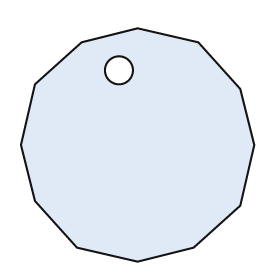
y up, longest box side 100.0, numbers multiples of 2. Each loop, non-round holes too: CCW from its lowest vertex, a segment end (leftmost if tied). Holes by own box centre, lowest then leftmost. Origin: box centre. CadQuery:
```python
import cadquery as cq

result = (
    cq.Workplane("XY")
    .moveTo(0.0, -50.0)
    .lineTo(24.0, -44.0)
    .lineTo(44.0, -26.0)
    .lineTo(50.0, 0.0)
    .lineTo(44.0, 24.0)
    .lineTo(26.0, 44.0)
    .lineTo(0.0, 50.0)
    .lineTo(-24.0, 44.0)
    .lineTo(-44.0, 26.0)
    .lineTo(-50.0, 0.0)
    .lineTo(-44.0, -24.0)
    .lineTo(-26.0, -44.0)
    .close()
    .moveTo(-8.0, 32.0)
    .circle(6.0)
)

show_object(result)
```